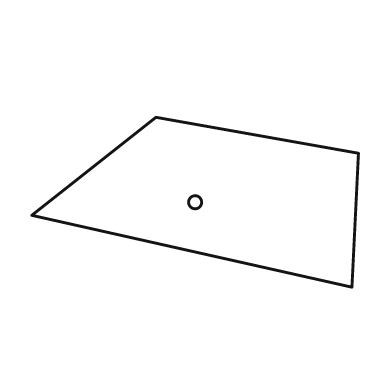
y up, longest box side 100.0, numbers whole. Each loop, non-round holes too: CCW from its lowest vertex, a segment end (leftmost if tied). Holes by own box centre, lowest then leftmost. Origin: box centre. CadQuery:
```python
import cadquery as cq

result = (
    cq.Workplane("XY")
    .moveTo(48.0, -26.0)
    .lineTo(50.0, 15.0)
    .lineTo(-12.0, 26.0)
    .lineTo(-50.0, -4.0)
    .close()
    .moveTo(0.0, 0.0)
    .circle(2.0)
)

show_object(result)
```